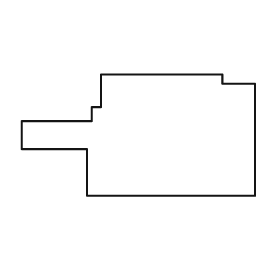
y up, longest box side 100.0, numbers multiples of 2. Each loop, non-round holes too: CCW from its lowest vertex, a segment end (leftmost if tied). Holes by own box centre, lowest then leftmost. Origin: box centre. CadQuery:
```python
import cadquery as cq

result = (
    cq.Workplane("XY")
    .moveTo(-22.0, -26.0)
    .lineTo(50.0, -26.0)
    .lineTo(50.0, 22.0)
    .lineTo(36.0, 22.0)
    .lineTo(36.0, 26.0)
    .lineTo(-16.0, 26.0)
    .lineTo(-16.0, 12.0)
    .lineTo(-20.0, 12.0)
    .lineTo(-20.0, 6.0)
    .lineTo(-50.0, 6.0)
    .lineTo(-50.0, -6.0)
    .lineTo(-22.0, -6.0)
    .close()
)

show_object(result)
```